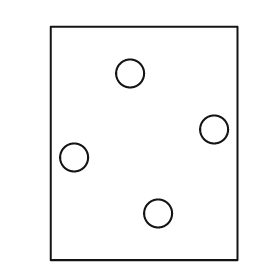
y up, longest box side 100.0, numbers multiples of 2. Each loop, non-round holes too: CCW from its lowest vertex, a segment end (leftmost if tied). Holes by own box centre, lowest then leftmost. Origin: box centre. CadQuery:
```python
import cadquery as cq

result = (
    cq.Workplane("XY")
    .moveTo(-40.0, -50.0)
    .lineTo(40.0, -50.0)
    .lineTo(40.0, 50.0)
    .lineTo(-40.0, 50.0)
    .close()
    .moveTo(6.0, -30.0)
    .circle(6.0)
    .moveTo(-30.0, -6.0)
    .circle(6.0)
    .moveTo(30.0, 6.0)
    .circle(6.0)
    .moveTo(-6.0, 30.0)
    .circle(6.0)
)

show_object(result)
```